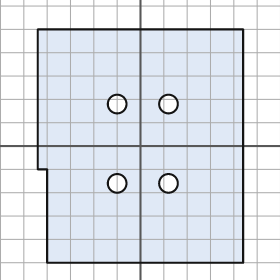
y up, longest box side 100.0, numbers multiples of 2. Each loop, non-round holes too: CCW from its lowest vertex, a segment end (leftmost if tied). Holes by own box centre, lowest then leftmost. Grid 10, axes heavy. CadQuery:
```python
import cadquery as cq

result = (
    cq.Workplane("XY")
    .moveTo(-40.0, -50.0)
    .lineTo(44.0, -50.0)
    .lineTo(44.0, 50.0)
    .lineTo(-44.0, 50.0)
    .lineTo(-44.0, -10.0)
    .lineTo(-40.0, -10.0)
    .close()
    .moveTo(-10.0, -16.0)
    .circle(4.0)
    .moveTo(12.0, -16.0)
    .circle(4.0)
    .moveTo(-10.0, 18.0)
    .circle(4.0)
    .moveTo(12.0, 18.0)
    .circle(4.0)
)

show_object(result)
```